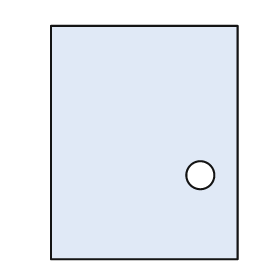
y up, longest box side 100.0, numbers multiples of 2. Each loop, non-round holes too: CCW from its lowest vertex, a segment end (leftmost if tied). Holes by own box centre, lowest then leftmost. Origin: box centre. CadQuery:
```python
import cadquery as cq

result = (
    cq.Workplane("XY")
    .moveTo(-40.0, -50.0)
    .lineTo(40.0, -50.0)
    .lineTo(40.0, 50.0)
    .lineTo(-40.0, 50.0)
    .close()
    .moveTo(24.0, -14.0)
    .circle(6.0)
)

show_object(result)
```